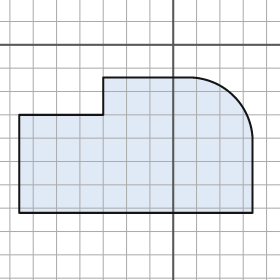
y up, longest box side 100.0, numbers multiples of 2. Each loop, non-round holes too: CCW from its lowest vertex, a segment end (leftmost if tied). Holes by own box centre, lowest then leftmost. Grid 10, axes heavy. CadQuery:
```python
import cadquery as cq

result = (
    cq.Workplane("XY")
    .moveTo(-66.0, -72.0)
    .lineTo(34.0, -72.0)
    .lineTo(34.0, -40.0)
    .threePointArc((26.0, -22.0), (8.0, -14.0))
    .lineTo(-30.0, -14.0)
    .lineTo(-30.0, -30.0)
    .lineTo(-66.0, -30.0)
    .close()
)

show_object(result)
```